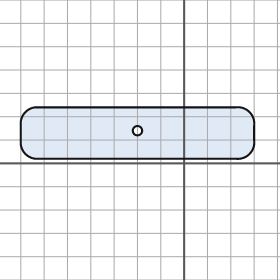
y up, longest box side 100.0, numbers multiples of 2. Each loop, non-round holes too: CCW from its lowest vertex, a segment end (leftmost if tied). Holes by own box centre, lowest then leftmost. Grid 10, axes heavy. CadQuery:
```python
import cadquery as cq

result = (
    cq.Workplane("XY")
    .moveTo(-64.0, 2.0)
    .lineTo(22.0, 2.0)
    .threePointArc((28.0, 4.0), (30.0, 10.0))
    .lineTo(30.0, 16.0)
    .threePointArc((28.0, 22.0), (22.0, 24.0))
    .lineTo(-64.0, 24.0)
    .threePointArc((-68.0, 22.0), (-70.0, 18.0))
    .lineTo(-70.0, 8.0)
    .threePointArc((-68.0, 4.0), (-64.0, 2.0))
    .close()
    .moveTo(-20.0, 14.0)
    .circle(2.0)
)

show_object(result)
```